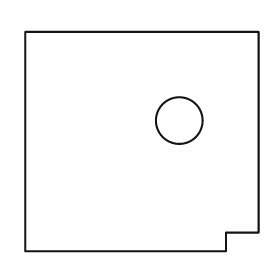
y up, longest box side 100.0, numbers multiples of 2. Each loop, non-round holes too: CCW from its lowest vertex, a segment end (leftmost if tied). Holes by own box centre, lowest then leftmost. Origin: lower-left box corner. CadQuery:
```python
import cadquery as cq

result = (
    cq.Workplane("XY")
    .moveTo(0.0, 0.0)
    .lineTo(86.0, 0.0)
    .lineTo(86.0, 8.0)
    .lineTo(100.0, 8.0)
    .lineTo(100.0, 94.0)
    .lineTo(0.0, 94.0)
    .close()
    .moveTo(66.0, 56.0)
    .circle(10.0)
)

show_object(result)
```